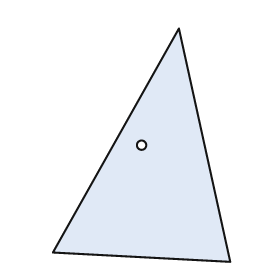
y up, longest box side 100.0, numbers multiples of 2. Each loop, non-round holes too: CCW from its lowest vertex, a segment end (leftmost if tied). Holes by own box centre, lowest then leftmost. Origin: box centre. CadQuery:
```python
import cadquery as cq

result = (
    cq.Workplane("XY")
    .moveTo(38.0, -50.0)
    .lineTo(16.0, 50.0)
    .lineTo(-38.0, -46.0)
    .close()
    .moveTo(0.0, 0.0)
    .circle(2.0)
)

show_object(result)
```